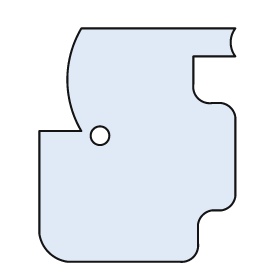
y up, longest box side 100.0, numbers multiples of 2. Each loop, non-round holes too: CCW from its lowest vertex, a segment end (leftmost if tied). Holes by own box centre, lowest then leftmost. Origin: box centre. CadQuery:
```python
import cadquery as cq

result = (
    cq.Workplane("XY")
    .moveTo(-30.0, -50.0)
    .lineTo(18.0, -50.0)
    .threePointArc((24.0, -48.0), (26.0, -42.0))
    .lineTo(26.0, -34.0)
    .threePointArc((28.0, -30.0), (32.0, -28.0))
    .lineTo(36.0, -28.0)
    .threePointArc((40.0, -26.0), (42.0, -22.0))
    .lineTo(42.0, 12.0)
    .threePointArc((40.0, 16.0), (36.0, 18.0))
    .lineTo(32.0, 18.0)
    .threePointArc((26.0, 20.0), (24.0, 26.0))
    .lineTo(24.0, 38.0)
    .lineTo(42.0, 38.0)
    .threePointArc((40.0, 44.0), (42.0, 50.0))
    .lineTo(-24.0, 50.0)
    .threePointArc((-30.0, 28.0), (-24.0, 6.0))
    .lineTo(-42.0, 6.0)
    .lineTo(-42.0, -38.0)
    .threePointArc((-38.0, -46.0), (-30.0, -50.0))
    .close()
    .moveTo(-16.0, 4.0)
    .circle(4.0)
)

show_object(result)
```